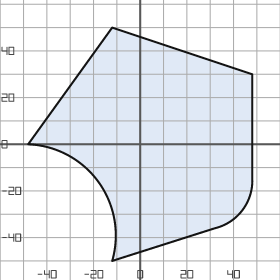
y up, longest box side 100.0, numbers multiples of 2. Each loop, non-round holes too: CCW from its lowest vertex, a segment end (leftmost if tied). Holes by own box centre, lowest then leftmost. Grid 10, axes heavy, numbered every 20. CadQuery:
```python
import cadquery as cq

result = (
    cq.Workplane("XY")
    .moveTo(-12.0, -50.0)
    .lineTo(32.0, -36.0)
    .threePointArc((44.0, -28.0), (48.0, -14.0))
    .lineTo(48.0, 30.0)
    .lineTo(-12.0, 50.0)
    .lineTo(-48.0, 0.0)
    .threePointArc((-18.0, -16.0), (-12.0, -50.0))
    .close()
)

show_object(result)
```